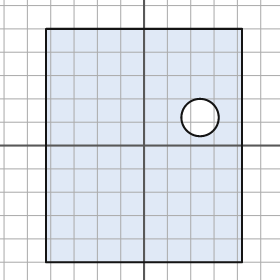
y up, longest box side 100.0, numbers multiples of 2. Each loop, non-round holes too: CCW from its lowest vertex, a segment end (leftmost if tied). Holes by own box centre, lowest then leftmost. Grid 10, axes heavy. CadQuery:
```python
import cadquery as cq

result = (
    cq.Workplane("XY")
    .moveTo(-42.0, -50.0)
    .lineTo(42.0, -50.0)
    .lineTo(42.0, 50.0)
    .lineTo(-42.0, 50.0)
    .close()
    .moveTo(24.0, 12.0)
    .circle(8.0)
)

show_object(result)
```